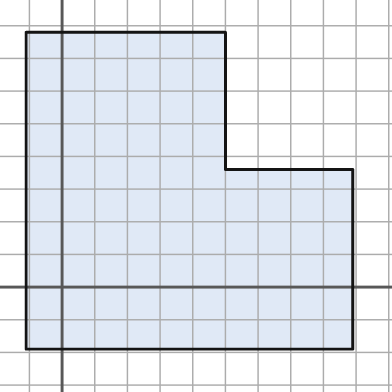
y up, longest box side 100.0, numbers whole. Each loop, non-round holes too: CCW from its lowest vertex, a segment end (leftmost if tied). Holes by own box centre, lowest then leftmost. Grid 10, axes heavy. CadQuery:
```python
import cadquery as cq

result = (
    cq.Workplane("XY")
    .moveTo(-11.0, -19.0)
    .lineTo(89.0, -19.0)
    .lineTo(89.0, 36.0)
    .lineTo(50.0, 36.0)
    .lineTo(50.0, 78.0)
    .lineTo(-11.0, 78.0)
    .close()
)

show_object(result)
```